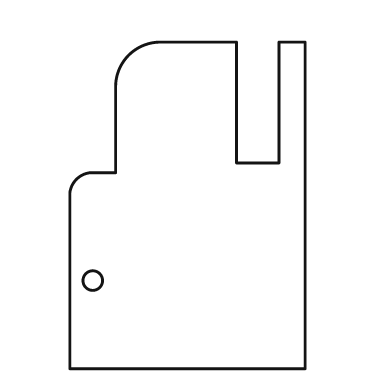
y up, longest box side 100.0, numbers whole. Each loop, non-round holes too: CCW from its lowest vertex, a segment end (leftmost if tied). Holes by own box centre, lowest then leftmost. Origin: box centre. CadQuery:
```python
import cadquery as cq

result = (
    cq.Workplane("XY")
    .moveTo(-36.0, -50.0)
    .lineTo(36.0, -50.0)
    .lineTo(36.0, 50.0)
    .lineTo(28.0, 50.0)
    .lineTo(28.0, 13.0)
    .lineTo(15.0, 13.0)
    .lineTo(15.0, 50.0)
    .lineTo(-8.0, 50.0)
    .threePointArc((-18.0, 46.0), (-22.0, 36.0))
    .lineTo(-22.0, 10.0)
    .lineTo(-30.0, 10.0)
    .threePointArc((-34.0, 8.0), (-36.0, 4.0))
    .close()
    .moveTo(-29.0, -23.0)
    .circle(3.0)
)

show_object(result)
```